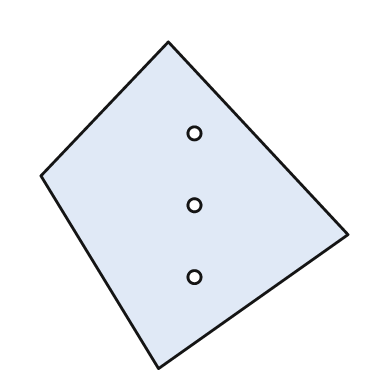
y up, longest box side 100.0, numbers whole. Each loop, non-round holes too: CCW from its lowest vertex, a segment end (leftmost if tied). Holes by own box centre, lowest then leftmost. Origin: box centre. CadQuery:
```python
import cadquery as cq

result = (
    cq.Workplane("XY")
    .moveTo(-11.0, -50.0)
    .lineTo(47.0, -9.0)
    .lineTo(-8.0, 50.0)
    .lineTo(-47.0, 9.0)
    .close()
    .moveTo(0.0, -22.0)
    .circle(2.0)
    .moveTo(0.0, 0.0)
    .circle(2.0)
    .moveTo(0.0, 22.0)
    .circle(2.0)
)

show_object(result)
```